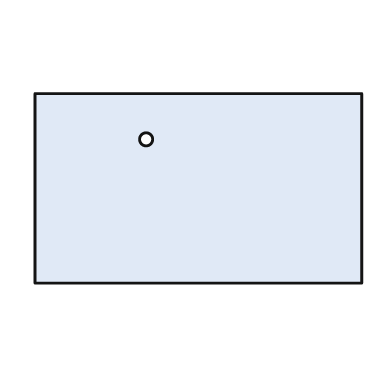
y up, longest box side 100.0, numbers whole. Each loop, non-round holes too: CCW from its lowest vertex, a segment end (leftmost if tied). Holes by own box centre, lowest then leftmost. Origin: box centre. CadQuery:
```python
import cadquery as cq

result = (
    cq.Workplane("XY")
    .moveTo(-50.0, -29.0)
    .lineTo(50.0, -29.0)
    .lineTo(50.0, 29.0)
    .lineTo(-50.0, 29.0)
    .close()
    .moveTo(-16.0, 15.0)
    .circle(2.0)
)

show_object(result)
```